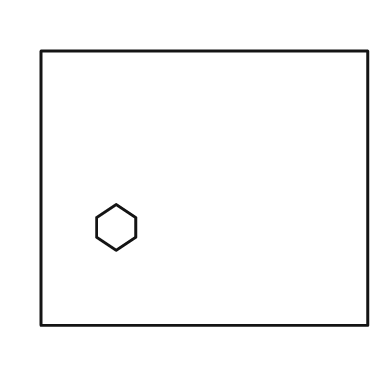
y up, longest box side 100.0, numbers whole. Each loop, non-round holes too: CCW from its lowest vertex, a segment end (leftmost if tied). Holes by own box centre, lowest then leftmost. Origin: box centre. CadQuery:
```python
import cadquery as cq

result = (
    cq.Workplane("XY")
    .moveTo(-50.0, -42.0)
    .lineTo(50.0, -42.0)
    .lineTo(50.0, 42.0)
    .lineTo(-50.0, 42.0)
    .close()
    .moveTo(-27.0, -19.0)
    .lineTo(-21.0, -15.0)
    .lineTo(-21.0, -9.0)
    .lineTo(-27.0, -5.0)
    .lineTo(-33.0, -9.0)
    .lineTo(-33.0, -15.0)
    .close()
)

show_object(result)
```